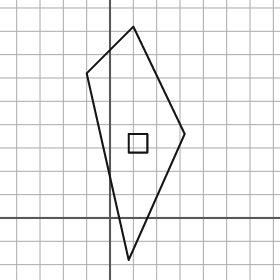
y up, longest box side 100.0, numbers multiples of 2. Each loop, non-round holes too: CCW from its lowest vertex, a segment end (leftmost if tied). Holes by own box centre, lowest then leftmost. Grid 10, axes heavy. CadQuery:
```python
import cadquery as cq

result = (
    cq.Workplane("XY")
    .moveTo(8.0, -18.0)
    .lineTo(32.0, 36.0)
    .lineTo(10.0, 82.0)
    .lineTo(-10.0, 62.0)
    .close()
    .moveTo(8.0, 28.0)
    .lineTo(16.0, 28.0)
    .lineTo(16.0, 36.0)
    .lineTo(8.0, 36.0)
    .close()
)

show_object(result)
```